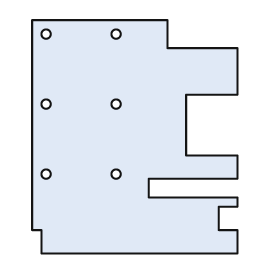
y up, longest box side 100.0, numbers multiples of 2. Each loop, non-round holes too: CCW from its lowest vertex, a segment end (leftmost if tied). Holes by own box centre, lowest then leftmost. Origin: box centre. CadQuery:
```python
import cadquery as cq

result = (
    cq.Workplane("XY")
    .moveTo(-40.0, -50.0)
    .lineTo(44.0, -50.0)
    .lineTo(44.0, -40.0)
    .lineTo(36.0, -40.0)
    .lineTo(36.0, -30.0)
    .lineTo(44.0, -30.0)
    .lineTo(44.0, -26.0)
    .lineTo(6.0, -26.0)
    .lineTo(6.0, -18.0)
    .lineTo(44.0, -18.0)
    .lineTo(44.0, -8.0)
    .lineTo(22.0, -8.0)
    .lineTo(22.0, 18.0)
    .lineTo(44.0, 18.0)
    .lineTo(44.0, 38.0)
    .lineTo(14.0, 38.0)
    .lineTo(14.0, 50.0)
    .lineTo(-44.0, 50.0)
    .lineTo(-44.0, -40.0)
    .lineTo(-40.0, -40.0)
    .close()
    .moveTo(-38.0, -16.0)
    .circle(2.0)
    .moveTo(-8.0, -16.0)
    .circle(2.0)
    .moveTo(-38.0, 14.0)
    .circle(2.0)
    .moveTo(-8.0, 14.0)
    .circle(2.0)
    .moveTo(-38.0, 44.0)
    .circle(2.0)
    .moveTo(-8.0, 44.0)
    .circle(2.0)
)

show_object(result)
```